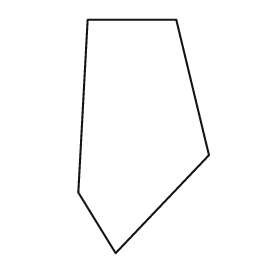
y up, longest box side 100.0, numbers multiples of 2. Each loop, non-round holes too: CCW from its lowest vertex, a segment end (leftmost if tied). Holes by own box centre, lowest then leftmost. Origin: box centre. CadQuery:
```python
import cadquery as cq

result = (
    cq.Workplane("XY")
    .moveTo(-12.0, -50.0)
    .lineTo(28.0, -8.0)
    .lineTo(14.0, 50.0)
    .lineTo(-24.0, 50.0)
    .lineTo(-28.0, -24.0)
    .close()
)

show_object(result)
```